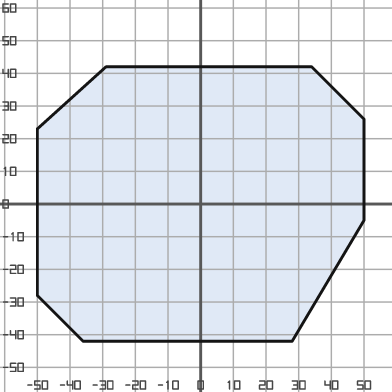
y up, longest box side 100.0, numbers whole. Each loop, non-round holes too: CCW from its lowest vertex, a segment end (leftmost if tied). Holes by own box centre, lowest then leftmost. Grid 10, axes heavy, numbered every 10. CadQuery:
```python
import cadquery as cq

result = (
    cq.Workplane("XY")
    .moveTo(-36.0, -42.0)
    .lineTo(28.0, -42.0)
    .lineTo(50.0, -5.0)
    .lineTo(50.0, 26.0)
    .lineTo(34.0, 42.0)
    .lineTo(-29.0, 42.0)
    .lineTo(-50.0, 23.0)
    .lineTo(-50.0, -28.0)
    .close()
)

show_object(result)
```